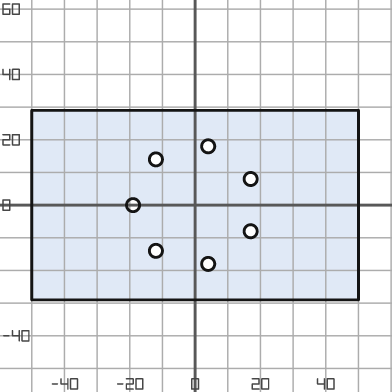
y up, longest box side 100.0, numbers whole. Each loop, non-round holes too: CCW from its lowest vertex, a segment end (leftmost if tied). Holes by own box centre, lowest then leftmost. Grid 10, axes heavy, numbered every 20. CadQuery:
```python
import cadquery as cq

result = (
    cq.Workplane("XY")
    .moveTo(-50.0, -29.0)
    .lineTo(50.0, -29.0)
    .lineTo(50.0, 29.0)
    .lineTo(-50.0, 29.0)
    .close()
    .moveTo(4.0, -18.0)
    .circle(2.0)
    .moveTo(-12.0, -14.0)
    .circle(2.0)
    .moveTo(17.0, -8.0)
    .circle(2.0)
    .moveTo(-19.0, 0.0)
    .circle(2.0)
    .moveTo(17.0, 8.0)
    .circle(2.0)
    .moveTo(-12.0, 14.0)
    .circle(2.0)
    .moveTo(4.0, 18.0)
    .circle(2.0)
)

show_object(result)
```